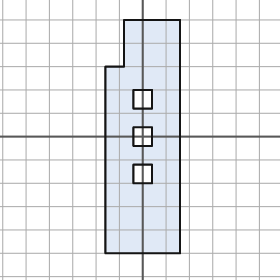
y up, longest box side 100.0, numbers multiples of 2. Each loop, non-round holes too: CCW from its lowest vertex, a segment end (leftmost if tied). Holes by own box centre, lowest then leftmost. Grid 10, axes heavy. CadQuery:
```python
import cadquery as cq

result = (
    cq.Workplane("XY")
    .moveTo(-16.0, -50.0)
    .lineTo(16.0, -50.0)
    .lineTo(16.0, 50.0)
    .lineTo(-8.0, 50.0)
    .lineTo(-8.0, 30.0)
    .lineTo(-16.0, 30.0)
    .close()
    .moveTo(-4.0, -20.0)
    .lineTo(4.0, -20.0)
    .lineTo(4.0, -12.0)
    .lineTo(-4.0, -12.0)
    .close()
    .moveTo(-4.0, -4.0)
    .lineTo(4.0, -4.0)
    .lineTo(4.0, 4.0)
    .lineTo(-4.0, 4.0)
    .close()
    .moveTo(-4.0, 12.0)
    .lineTo(4.0, 12.0)
    .lineTo(4.0, 20.0)
    .lineTo(-4.0, 20.0)
    .close()
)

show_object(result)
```